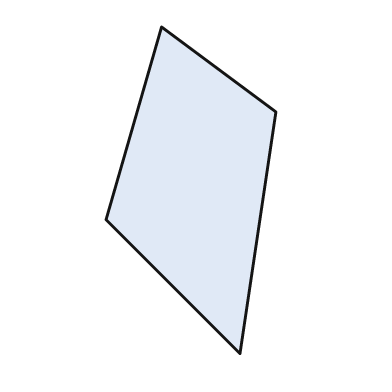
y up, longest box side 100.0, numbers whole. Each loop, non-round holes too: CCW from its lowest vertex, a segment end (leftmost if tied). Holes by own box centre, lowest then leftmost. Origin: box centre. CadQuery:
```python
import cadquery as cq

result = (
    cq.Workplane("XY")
    .moveTo(15.0, -50.0)
    .lineTo(26.0, 24.0)
    .lineTo(-9.0, 50.0)
    .lineTo(-26.0, -9.0)
    .close()
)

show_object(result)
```